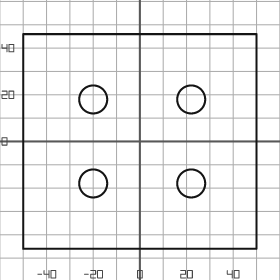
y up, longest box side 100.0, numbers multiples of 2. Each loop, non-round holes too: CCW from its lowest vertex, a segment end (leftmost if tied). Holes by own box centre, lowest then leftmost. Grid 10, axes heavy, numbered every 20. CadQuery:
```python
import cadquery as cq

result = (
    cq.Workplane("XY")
    .moveTo(-50.0, -46.0)
    .lineTo(50.0, -46.0)
    .lineTo(50.0, 46.0)
    .lineTo(-50.0, 46.0)
    .close()
    .moveTo(-20.0, -18.0)
    .circle(6.0)
    .moveTo(22.0, -18.0)
    .circle(6.0)
    .moveTo(-20.0, 18.0)
    .circle(6.0)
    .moveTo(22.0, 18.0)
    .circle(6.0)
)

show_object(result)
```